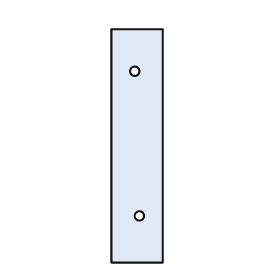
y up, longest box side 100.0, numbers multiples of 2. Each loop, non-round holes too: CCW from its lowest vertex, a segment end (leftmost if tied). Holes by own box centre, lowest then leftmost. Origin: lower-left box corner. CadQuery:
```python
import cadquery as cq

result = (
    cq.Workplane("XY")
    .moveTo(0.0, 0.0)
    .lineTo(22.0, 0.0)
    .lineTo(22.0, 100.0)
    .lineTo(0.0, 100.0)
    .close()
    .moveTo(12.0, 20.0)
    .circle(2.0)
    .moveTo(10.0, 82.0)
    .circle(2.0)
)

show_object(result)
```